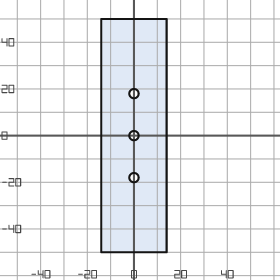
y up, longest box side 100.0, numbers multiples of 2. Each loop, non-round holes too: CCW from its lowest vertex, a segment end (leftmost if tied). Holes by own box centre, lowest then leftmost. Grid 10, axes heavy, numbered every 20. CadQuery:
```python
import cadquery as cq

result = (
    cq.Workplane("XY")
    .moveTo(-14.0, -50.0)
    .lineTo(14.0, -50.0)
    .lineTo(14.0, 50.0)
    .lineTo(-14.0, 50.0)
    .close()
    .moveTo(0.0, -18.0)
    .circle(2.0)
    .moveTo(0.0, 0.0)
    .circle(2.0)
    .moveTo(0.0, 18.0)
    .circle(2.0)
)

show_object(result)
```